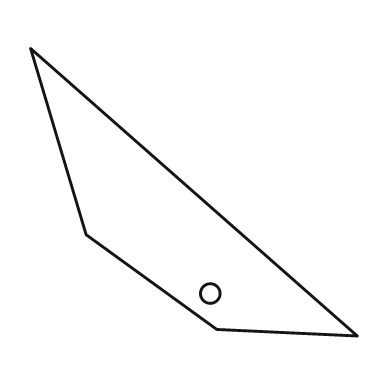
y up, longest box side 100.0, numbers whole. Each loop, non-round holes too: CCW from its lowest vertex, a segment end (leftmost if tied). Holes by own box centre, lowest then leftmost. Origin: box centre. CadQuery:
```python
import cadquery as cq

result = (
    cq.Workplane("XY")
    .moveTo(50.0, -44.0)
    .lineTo(-50.0, 44.0)
    .lineTo(-33.0, -13.0)
    .lineTo(7.0, -42.0)
    .close()
    .moveTo(5.0, -31.0)
    .circle(3.0)
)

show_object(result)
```